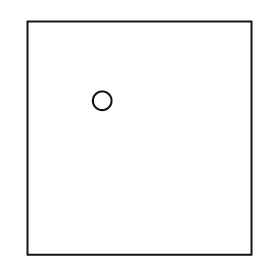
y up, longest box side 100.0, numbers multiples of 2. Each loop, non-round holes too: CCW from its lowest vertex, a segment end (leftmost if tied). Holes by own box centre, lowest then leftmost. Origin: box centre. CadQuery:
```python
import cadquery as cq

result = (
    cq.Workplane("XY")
    .moveTo(-48.0, -50.0)
    .lineTo(48.0, -50.0)
    .lineTo(48.0, 50.0)
    .lineTo(-48.0, 50.0)
    .close()
    .moveTo(-16.0, 16.0)
    .circle(4.0)
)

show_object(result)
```